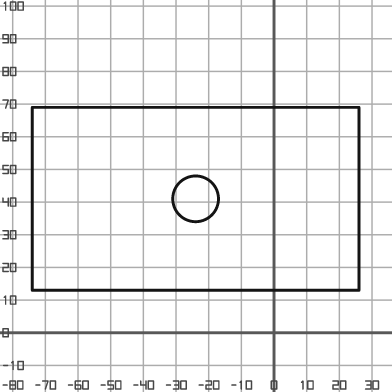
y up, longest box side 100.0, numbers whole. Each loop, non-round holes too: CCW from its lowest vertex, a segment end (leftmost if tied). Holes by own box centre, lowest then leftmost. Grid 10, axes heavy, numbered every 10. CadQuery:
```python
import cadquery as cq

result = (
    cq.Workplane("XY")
    .moveTo(-74.0, 13.0)
    .lineTo(26.0, 13.0)
    .lineTo(26.0, 69.0)
    .lineTo(-74.0, 69.0)
    .close()
    .moveTo(-24.0, 41.0)
    .circle(7.0)
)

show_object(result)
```